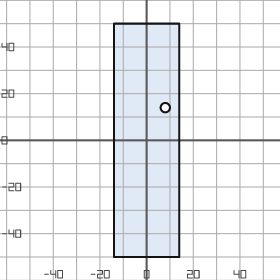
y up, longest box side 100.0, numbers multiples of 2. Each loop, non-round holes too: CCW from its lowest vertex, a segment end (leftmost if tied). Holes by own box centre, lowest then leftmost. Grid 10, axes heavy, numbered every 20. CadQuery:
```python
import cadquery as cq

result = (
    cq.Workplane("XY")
    .moveTo(-14.0, -50.0)
    .lineTo(14.0, -50.0)
    .lineTo(14.0, 50.0)
    .lineTo(-14.0, 50.0)
    .close()
    .moveTo(8.0, 14.0)
    .circle(2.0)
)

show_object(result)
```